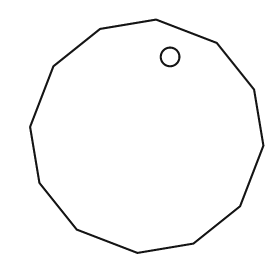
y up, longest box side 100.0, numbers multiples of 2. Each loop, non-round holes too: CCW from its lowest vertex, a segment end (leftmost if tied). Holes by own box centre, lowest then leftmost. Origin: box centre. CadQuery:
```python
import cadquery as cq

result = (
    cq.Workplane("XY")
    .moveTo(-4.0, -50.0)
    .lineTo(20.0, -46.0)
    .lineTo(40.0, -30.0)
    .lineTo(50.0, -4.0)
    .lineTo(46.0, 20.0)
    .lineTo(30.0, 40.0)
    .lineTo(4.0, 50.0)
    .lineTo(-20.0, 46.0)
    .lineTo(-40.0, 30.0)
    .lineTo(-50.0, 4.0)
    .lineTo(-46.0, -20.0)
    .lineTo(-30.0, -40.0)
    .close()
    .moveTo(10.0, 34.0)
    .circle(4.0)
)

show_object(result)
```